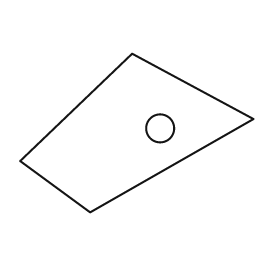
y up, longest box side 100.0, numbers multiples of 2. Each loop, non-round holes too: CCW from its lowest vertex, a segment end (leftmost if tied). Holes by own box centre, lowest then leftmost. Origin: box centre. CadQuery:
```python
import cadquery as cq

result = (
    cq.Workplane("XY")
    .moveTo(-20.0, -34.0)
    .lineTo(50.0, 6.0)
    .lineTo(-2.0, 34.0)
    .lineTo(-50.0, -12.0)
    .close()
    .moveTo(10.0, 2.0)
    .circle(6.0)
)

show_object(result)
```